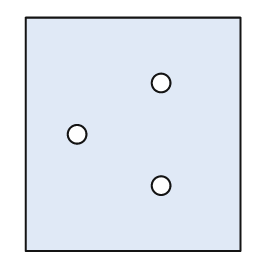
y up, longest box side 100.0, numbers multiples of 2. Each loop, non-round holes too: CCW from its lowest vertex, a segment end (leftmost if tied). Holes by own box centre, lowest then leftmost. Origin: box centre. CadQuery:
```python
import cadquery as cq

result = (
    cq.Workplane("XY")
    .moveTo(-46.0, -50.0)
    .lineTo(46.0, -50.0)
    .lineTo(46.0, 50.0)
    .lineTo(-46.0, 50.0)
    .close()
    .moveTo(12.0, -22.0)
    .circle(4.0)
    .moveTo(-24.0, 0.0)
    .circle(4.0)
    .moveTo(12.0, 22.0)
    .circle(4.0)
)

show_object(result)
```